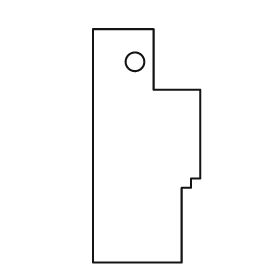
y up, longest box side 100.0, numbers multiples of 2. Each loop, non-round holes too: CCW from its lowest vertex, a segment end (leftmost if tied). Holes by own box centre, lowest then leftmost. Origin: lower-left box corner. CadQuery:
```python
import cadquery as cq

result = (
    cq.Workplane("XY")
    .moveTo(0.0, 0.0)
    .lineTo(38.0, 0.0)
    .lineTo(38.0, 32.0)
    .lineTo(42.0, 32.0)
    .lineTo(42.0, 36.0)
    .lineTo(46.0, 36.0)
    .lineTo(46.0, 74.0)
    .lineTo(26.0, 74.0)
    .lineTo(26.0, 100.0)
    .lineTo(0.0, 100.0)
    .close()
    .moveTo(18.0, 86.0)
    .circle(4.0)
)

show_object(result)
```